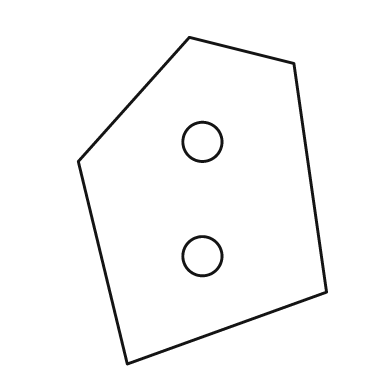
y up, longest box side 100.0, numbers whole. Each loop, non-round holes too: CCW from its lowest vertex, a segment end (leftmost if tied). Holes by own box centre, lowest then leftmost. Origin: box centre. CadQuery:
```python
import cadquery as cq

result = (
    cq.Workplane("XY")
    .moveTo(-23.0, -50.0)
    .lineTo(38.0, -28.0)
    .lineTo(28.0, 42.0)
    .lineTo(-4.0, 50.0)
    .lineTo(-38.0, 12.0)
    .close()
    .moveTo(0.0, -17.0)
    .circle(6.0)
    .moveTo(0.0, 18.0)
    .circle(6.0)
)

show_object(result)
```